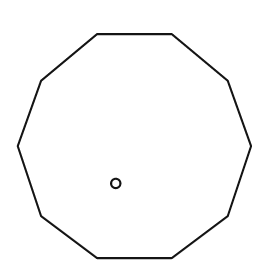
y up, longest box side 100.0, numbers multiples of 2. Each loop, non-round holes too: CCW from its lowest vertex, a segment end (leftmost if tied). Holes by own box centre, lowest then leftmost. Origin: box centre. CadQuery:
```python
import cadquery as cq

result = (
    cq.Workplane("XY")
    .moveTo(-16.0, -48.0)
    .lineTo(16.0, -48.0)
    .lineTo(40.0, -30.0)
    .lineTo(50.0, 0.0)
    .lineTo(40.0, 28.0)
    .lineTo(16.0, 48.0)
    .lineTo(-16.0, 48.0)
    .lineTo(-40.0, 28.0)
    .lineTo(-50.0, 0.0)
    .lineTo(-40.0, -30.0)
    .close()
    .moveTo(-8.0, -16.0)
    .circle(2.0)
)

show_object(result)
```